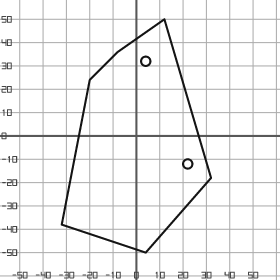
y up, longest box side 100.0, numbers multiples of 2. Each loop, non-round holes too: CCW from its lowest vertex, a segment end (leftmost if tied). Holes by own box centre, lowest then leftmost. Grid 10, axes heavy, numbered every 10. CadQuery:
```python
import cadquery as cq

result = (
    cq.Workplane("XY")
    .moveTo(4.0, -50.0)
    .lineTo(32.0, -18.0)
    .lineTo(12.0, 50.0)
    .lineTo(-8.0, 36.0)
    .lineTo(-20.0, 24.0)
    .lineTo(-32.0, -38.0)
    .close()
    .moveTo(22.0, -12.0)
    .circle(2.0)
    .moveTo(4.0, 32.0)
    .circle(2.0)
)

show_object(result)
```